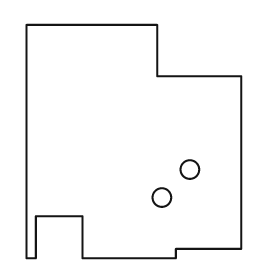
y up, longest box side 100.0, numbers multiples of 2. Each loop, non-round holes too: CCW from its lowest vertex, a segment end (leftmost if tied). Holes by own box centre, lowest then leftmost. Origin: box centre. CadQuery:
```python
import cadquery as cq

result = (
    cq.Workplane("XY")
    .moveTo(-46.0, -50.0)
    .lineTo(-42.0, -50.0)
    .lineTo(-42.0, -32.0)
    .lineTo(-22.0, -32.0)
    .lineTo(-22.0, -50.0)
    .lineTo(18.0, -50.0)
    .lineTo(18.0, -46.0)
    .lineTo(46.0, -46.0)
    .lineTo(46.0, 28.0)
    .lineTo(10.0, 28.0)
    .lineTo(10.0, 50.0)
    .lineTo(-46.0, 50.0)
    .close()
    .moveTo(12.0, -24.0)
    .circle(4.0)
    .moveTo(24.0, -12.0)
    .circle(4.0)
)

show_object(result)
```